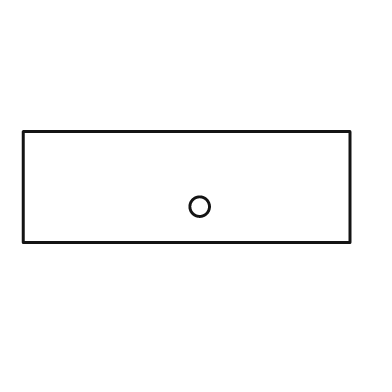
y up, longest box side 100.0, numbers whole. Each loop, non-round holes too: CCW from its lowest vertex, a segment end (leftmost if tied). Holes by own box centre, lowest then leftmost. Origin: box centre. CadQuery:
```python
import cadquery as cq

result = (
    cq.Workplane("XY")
    .moveTo(-50.0, -17.0)
    .lineTo(50.0, -17.0)
    .lineTo(50.0, 17.0)
    .lineTo(-50.0, 17.0)
    .close()
    .moveTo(4.0, -6.0)
    .circle(3.0)
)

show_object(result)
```